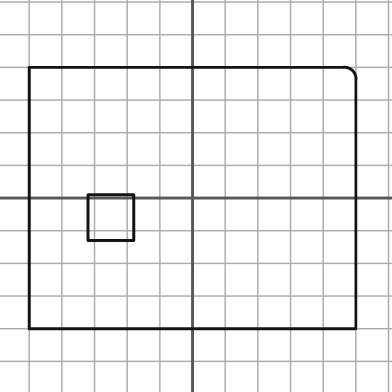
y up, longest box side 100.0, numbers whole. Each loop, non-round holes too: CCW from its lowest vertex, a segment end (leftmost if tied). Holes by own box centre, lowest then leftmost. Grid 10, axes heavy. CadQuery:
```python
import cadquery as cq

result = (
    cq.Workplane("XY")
    .moveTo(-50.0, -40.0)
    .lineTo(50.0, -40.0)
    .lineTo(50.0, 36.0)
    .threePointArc((49.0, 39.0), (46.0, 40.0))
    .lineTo(-50.0, 40.0)
    .close()
    .moveTo(-32.0, -13.0)
    .lineTo(-18.0, -13.0)
    .lineTo(-18.0, 1.0)
    .lineTo(-32.0, 1.0)
    .close()
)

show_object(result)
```